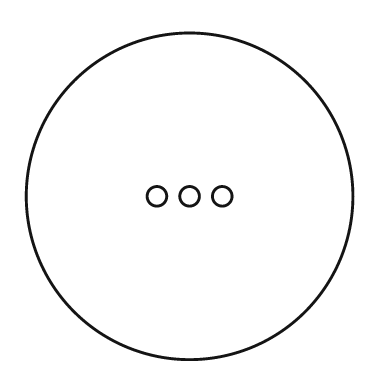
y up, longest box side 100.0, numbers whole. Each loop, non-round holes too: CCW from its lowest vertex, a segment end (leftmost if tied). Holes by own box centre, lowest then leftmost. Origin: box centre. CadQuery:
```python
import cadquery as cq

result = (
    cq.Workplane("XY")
    .moveTo(0.0, 0.0)
    .circle(50.0)
    .moveTo(-10.0, 0.0)
    .circle(3.0)
    .moveTo(0.0, 0.0)
    .circle(3.0)
    .moveTo(10.0, 0.0)
    .circle(3.0)
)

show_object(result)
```